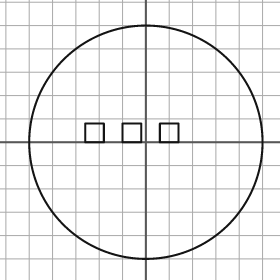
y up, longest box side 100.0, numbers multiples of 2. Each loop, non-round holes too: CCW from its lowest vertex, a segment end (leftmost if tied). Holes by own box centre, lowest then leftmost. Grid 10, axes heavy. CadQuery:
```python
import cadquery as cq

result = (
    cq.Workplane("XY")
    .moveTo(0.0, 0.0)
    .circle(50.0)
    .moveTo(-26.0, 0.0)
    .lineTo(-18.0, 0.0)
    .lineTo(-18.0, 8.0)
    .lineTo(-26.0, 8.0)
    .close()
    .moveTo(-10.0, 0.0)
    .lineTo(-2.0, 0.0)
    .lineTo(-2.0, 8.0)
    .lineTo(-10.0, 8.0)
    .close()
    .moveTo(6.0, 0.0)
    .lineTo(14.0, 0.0)
    .lineTo(14.0, 8.0)
    .lineTo(6.0, 8.0)
    .close()
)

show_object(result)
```